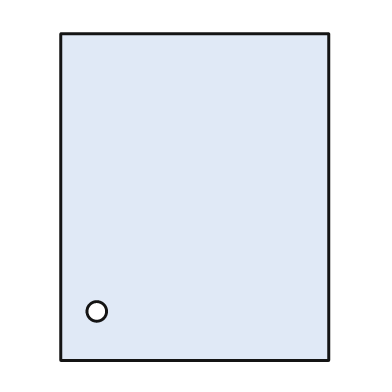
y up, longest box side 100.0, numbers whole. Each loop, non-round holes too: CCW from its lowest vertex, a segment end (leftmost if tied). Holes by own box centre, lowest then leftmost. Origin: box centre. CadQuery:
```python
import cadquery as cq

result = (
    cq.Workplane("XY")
    .moveTo(-41.0, -50.0)
    .lineTo(41.0, -50.0)
    .lineTo(41.0, 50.0)
    .lineTo(-41.0, 50.0)
    .close()
    .moveTo(-30.0, -35.0)
    .circle(3.0)
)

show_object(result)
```